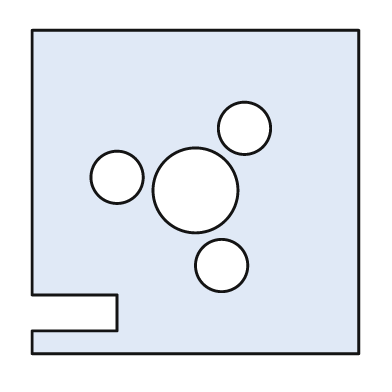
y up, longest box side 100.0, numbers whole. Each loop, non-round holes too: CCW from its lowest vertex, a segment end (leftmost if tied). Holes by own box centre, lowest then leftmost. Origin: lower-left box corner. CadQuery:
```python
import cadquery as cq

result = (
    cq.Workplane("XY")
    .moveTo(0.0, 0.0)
    .lineTo(100.0, 0.0)
    .lineTo(100.0, 99.0)
    .lineTo(0.0, 99.0)
    .lineTo(0.0, 18.0)
    .lineTo(26.0, 18.0)
    .lineTo(26.0, 7.0)
    .lineTo(0.0, 7.0)
    .close()
    .moveTo(58.0, 27.0)
    .circle(8.0)
    .moveTo(50.0, 50.0)
    .circle(13.0)
    .moveTo(26.0, 54.0)
    .circle(8.0)
    .moveTo(65.0, 69.0)
    .circle(8.0)
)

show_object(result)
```